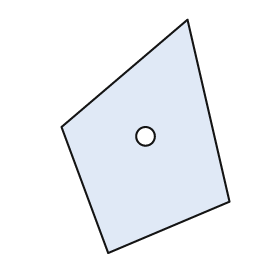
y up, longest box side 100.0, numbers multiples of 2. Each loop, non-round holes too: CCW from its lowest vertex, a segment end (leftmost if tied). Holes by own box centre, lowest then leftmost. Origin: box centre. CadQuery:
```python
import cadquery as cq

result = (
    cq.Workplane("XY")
    .moveTo(-16.0, -50.0)
    .lineTo(36.0, -28.0)
    .lineTo(18.0, 50.0)
    .lineTo(-36.0, 4.0)
    .close()
    .moveTo(0.0, 0.0)
    .circle(4.0)
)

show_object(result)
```